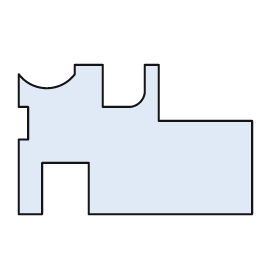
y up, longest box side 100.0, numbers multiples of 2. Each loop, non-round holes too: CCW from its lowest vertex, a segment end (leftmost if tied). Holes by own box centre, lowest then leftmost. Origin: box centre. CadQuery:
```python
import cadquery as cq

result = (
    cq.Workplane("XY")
    .moveTo(-50.0, -32.0)
    .lineTo(-40.0, -32.0)
    .lineTo(-40.0, -10.0)
    .lineTo(-20.0, -10.0)
    .lineTo(-20.0, -32.0)
    .lineTo(50.0, -32.0)
    .lineTo(50.0, 8.0)
    .lineTo(10.0, 8.0)
    .lineTo(10.0, 32.0)
    .lineTo(4.0, 32.0)
    .lineTo(4.0, 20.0)
    .threePointArc((2.0, 16.0), (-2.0, 14.0))
    .lineTo(-14.0, 14.0)
    .lineTo(-14.0, 32.0)
    .lineTo(-26.0, 32.0)
    .lineTo(-26.0, 28.0)
    .threePointArc((-38.0, 22.0), (-50.0, 28.0))
    .lineTo(-50.0, 14.0)
    .lineTo(-46.0, 14.0)
    .lineTo(-46.0, 0.0)
    .lineTo(-50.0, 0.0)
    .close()
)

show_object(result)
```